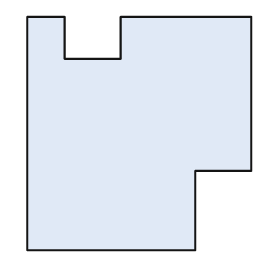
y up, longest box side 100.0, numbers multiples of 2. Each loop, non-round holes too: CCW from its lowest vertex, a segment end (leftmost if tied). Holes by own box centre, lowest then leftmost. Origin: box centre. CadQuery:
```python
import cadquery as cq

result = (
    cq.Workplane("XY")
    .moveTo(-48.0, -50.0)
    .lineTo(24.0, -50.0)
    .lineTo(24.0, -16.0)
    .lineTo(48.0, -16.0)
    .lineTo(48.0, 50.0)
    .lineTo(-8.0, 50.0)
    .lineTo(-8.0, 32.0)
    .lineTo(-32.0, 32.0)
    .lineTo(-32.0, 50.0)
    .lineTo(-48.0, 50.0)
    .close()
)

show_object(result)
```